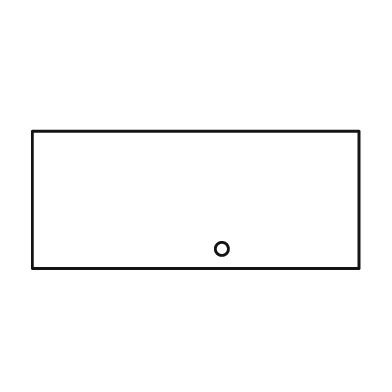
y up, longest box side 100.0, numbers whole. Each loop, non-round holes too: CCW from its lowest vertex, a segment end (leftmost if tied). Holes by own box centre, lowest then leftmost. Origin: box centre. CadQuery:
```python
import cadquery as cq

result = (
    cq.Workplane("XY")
    .moveTo(-50.0, -21.0)
    .lineTo(50.0, -21.0)
    .lineTo(50.0, 21.0)
    .lineTo(-50.0, 21.0)
    .close()
    .moveTo(8.0, -15.0)
    .circle(2.0)
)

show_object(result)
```